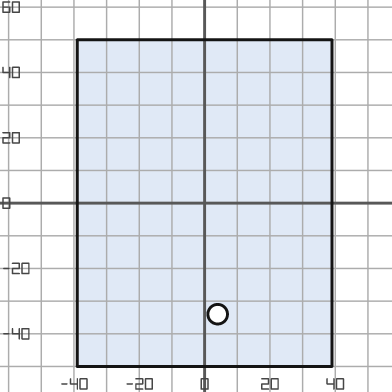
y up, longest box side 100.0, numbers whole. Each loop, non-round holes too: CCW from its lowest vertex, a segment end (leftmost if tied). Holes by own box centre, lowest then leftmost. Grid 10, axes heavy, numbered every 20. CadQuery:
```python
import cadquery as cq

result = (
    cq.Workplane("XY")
    .moveTo(-39.0, -50.0)
    .lineTo(39.0, -50.0)
    .lineTo(39.0, 50.0)
    .lineTo(-39.0, 50.0)
    .close()
    .moveTo(4.0, -34.0)
    .circle(3.0)
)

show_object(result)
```